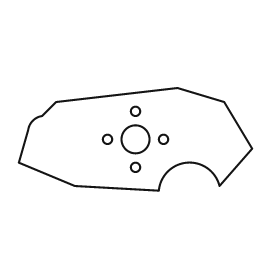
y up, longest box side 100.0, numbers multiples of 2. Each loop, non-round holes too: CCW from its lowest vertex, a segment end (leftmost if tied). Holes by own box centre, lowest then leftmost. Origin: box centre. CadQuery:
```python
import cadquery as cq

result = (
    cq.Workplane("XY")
    .moveTo(10.0, -22.0)
    .threePointArc((22.0, -10.0), (36.0, -20.0))
    .lineTo(50.0, -4.0)
    .lineTo(38.0, 16.0)
    .lineTo(18.0, 22.0)
    .lineTo(-34.0, 16.0)
    .lineTo(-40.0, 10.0)
    .threePointArc((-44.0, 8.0), (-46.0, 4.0))
    .lineTo(-50.0, -10.0)
    .lineTo(-26.0, -20.0)
    .close()
    .moveTo(0.0, -12.0)
    .circle(2.0)
    .moveTo(-12.0, 0.0)
    .circle(2.0)
    .moveTo(0.0, 0.0)
    .circle(6.0)
    .moveTo(12.0, 0.0)
    .circle(2.0)
    .moveTo(0.0, 12.0)
    .circle(2.0)
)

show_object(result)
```